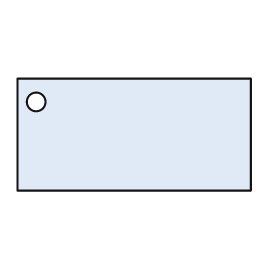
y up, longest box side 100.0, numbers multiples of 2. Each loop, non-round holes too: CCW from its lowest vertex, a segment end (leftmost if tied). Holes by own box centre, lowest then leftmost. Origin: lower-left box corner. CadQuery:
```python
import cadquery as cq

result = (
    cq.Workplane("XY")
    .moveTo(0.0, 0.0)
    .lineTo(100.0, 0.0)
    .lineTo(100.0, 48.0)
    .lineTo(0.0, 48.0)
    .close()
    .moveTo(8.0, 38.0)
    .circle(4.0)
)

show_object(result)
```